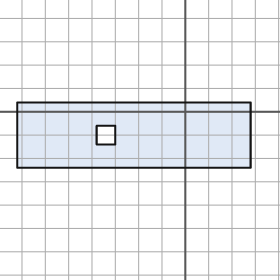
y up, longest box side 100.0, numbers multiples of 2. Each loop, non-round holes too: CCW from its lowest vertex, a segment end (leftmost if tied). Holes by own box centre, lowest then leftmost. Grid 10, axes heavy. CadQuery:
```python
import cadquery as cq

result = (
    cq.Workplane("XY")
    .moveTo(-72.0, -24.0)
    .lineTo(28.0, -24.0)
    .lineTo(28.0, 4.0)
    .lineTo(-72.0, 4.0)
    .close()
    .moveTo(-38.0, -14.0)
    .lineTo(-30.0, -14.0)
    .lineTo(-30.0, -6.0)
    .lineTo(-38.0, -6.0)
    .close()
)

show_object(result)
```